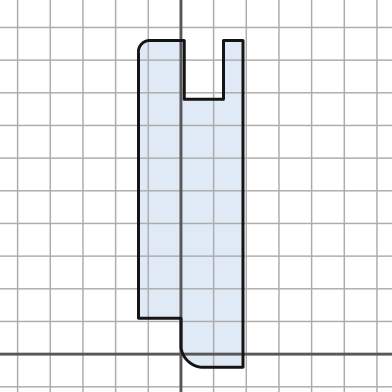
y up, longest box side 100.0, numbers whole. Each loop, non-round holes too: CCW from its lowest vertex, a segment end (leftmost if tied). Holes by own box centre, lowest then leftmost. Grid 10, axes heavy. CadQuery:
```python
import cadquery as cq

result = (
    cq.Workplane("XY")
    .moveTo(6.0, -4.0)
    .lineTo(19.0, -4.0)
    .lineTo(19.0, 96.0)
    .lineTo(13.0, 96.0)
    .lineTo(13.0, 78.0)
    .lineTo(1.0, 78.0)
    .lineTo(1.0, 96.0)
    .lineTo(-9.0, 96.0)
    .threePointArc((-12.0, 95.0), (-13.0, 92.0))
    .lineTo(-13.0, 11.0)
    .lineTo(0.0, 11.0)
    .lineTo(0.0, 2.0)
    .threePointArc((2.0, -2.0), (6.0, -4.0))
    .close()
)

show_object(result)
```